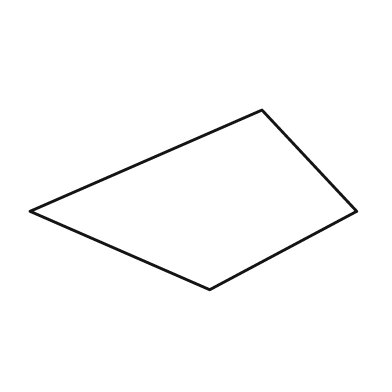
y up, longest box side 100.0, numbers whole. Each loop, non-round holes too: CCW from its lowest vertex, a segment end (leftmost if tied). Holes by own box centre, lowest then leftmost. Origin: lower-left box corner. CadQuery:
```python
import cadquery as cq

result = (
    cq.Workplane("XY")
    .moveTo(55.0, 0.0)
    .lineTo(100.0, 24.0)
    .lineTo(71.0, 55.0)
    .lineTo(0.0, 24.0)
    .close()
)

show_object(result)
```